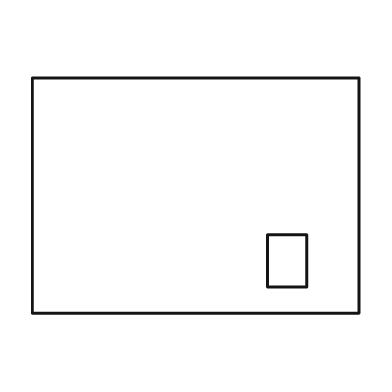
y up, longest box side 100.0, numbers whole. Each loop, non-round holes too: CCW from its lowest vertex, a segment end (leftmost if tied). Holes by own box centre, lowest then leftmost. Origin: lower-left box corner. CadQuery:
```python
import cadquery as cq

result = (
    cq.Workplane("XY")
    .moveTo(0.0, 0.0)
    .lineTo(100.0, 0.0)
    .lineTo(100.0, 72.0)
    .lineTo(0.0, 72.0)
    .close()
    .moveTo(72.0, 8.0)
    .lineTo(84.0, 8.0)
    .lineTo(84.0, 24.0)
    .lineTo(72.0, 24.0)
    .close()
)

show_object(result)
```